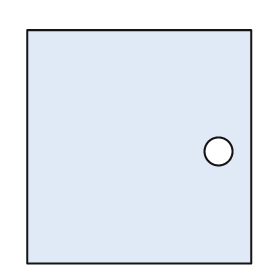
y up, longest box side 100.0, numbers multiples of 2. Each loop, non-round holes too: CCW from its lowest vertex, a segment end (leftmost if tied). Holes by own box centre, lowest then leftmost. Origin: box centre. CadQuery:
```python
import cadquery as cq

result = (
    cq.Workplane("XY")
    .moveTo(-48.0, -50.0)
    .lineTo(48.0, -50.0)
    .lineTo(48.0, 50.0)
    .lineTo(-48.0, 50.0)
    .close()
    .moveTo(34.0, -2.0)
    .circle(6.0)
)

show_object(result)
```